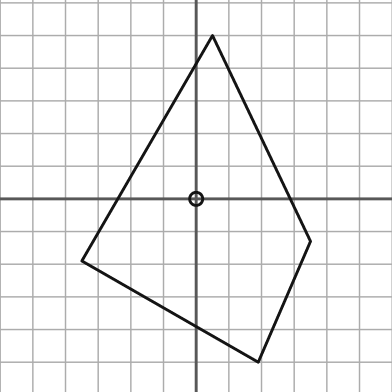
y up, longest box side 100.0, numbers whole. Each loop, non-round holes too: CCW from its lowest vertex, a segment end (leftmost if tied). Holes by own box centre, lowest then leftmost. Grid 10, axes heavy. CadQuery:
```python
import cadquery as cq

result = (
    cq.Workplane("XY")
    .moveTo(19.0, -50.0)
    .lineTo(35.0, -13.0)
    .lineTo(5.0, 50.0)
    .lineTo(-35.0, -19.0)
    .close()
    .moveTo(0.0, 0.0)
    .circle(2.0)
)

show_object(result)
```